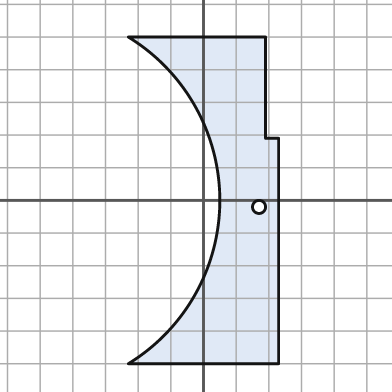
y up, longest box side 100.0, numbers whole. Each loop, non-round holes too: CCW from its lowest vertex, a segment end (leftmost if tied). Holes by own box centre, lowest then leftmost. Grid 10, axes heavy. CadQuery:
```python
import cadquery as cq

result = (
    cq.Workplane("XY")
    .moveTo(-23.0, -50.0)
    .lineTo(23.0, -50.0)
    .lineTo(23.0, 19.0)
    .lineTo(19.0, 19.0)
    .lineTo(19.0, 50.0)
    .lineTo(-23.0, 50.0)
    .threePointArc((5.0, 0.0), (-23.0, -50.0))
    .close()
    .moveTo(17.0, -2.0)
    .circle(2.0)
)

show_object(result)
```